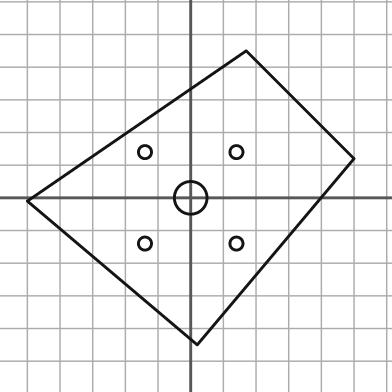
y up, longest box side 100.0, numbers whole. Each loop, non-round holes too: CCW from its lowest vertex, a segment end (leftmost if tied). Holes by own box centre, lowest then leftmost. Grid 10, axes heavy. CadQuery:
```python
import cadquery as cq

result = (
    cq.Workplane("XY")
    .moveTo(2.0, -45.0)
    .lineTo(50.0, 12.0)
    .lineTo(17.0, 45.0)
    .lineTo(-50.0, -1.0)
    .close()
    .moveTo(-14.0, -14.0)
    .circle(2.0)
    .moveTo(14.0, -14.0)
    .circle(2.0)
    .moveTo(0.0, 0.0)
    .circle(5.0)
    .moveTo(-14.0, 14.0)
    .circle(2.0)
    .moveTo(14.0, 14.0)
    .circle(2.0)
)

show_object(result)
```